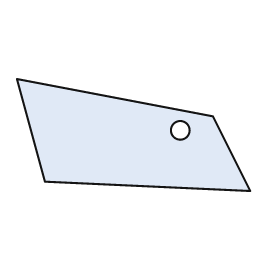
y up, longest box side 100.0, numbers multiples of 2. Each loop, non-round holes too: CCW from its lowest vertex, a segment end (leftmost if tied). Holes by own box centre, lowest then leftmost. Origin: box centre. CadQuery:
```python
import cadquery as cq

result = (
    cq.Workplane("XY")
    .moveTo(50.0, -24.0)
    .lineTo(34.0, 8.0)
    .lineTo(-50.0, 24.0)
    .lineTo(-38.0, -20.0)
    .close()
    .moveTo(20.0, 2.0)
    .circle(4.0)
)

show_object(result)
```